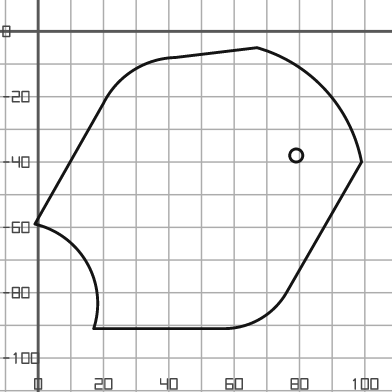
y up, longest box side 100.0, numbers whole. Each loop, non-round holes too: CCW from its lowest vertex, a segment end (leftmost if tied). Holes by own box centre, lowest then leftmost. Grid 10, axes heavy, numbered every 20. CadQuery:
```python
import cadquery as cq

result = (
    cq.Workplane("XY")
    .moveTo(17.0, -91.0)
    .lineTo(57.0, -91.0)
    .threePointArc((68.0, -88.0), (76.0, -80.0))
    .lineTo(99.0, -40.0)
    .threePointArc((88.0, -18.0), (67.0, -5.0))
    .lineTo(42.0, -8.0)
    .threePointArc((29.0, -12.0), (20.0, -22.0))
    .lineTo(-1.0, -59.0)
    .threePointArc((15.0, -71.0), (17.0, -91.0))
    .close()
    .moveTo(79.0, -38.0)
    .circle(2.0)
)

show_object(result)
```